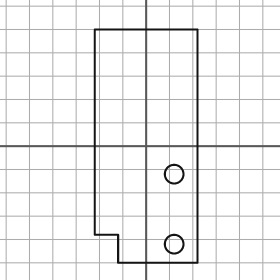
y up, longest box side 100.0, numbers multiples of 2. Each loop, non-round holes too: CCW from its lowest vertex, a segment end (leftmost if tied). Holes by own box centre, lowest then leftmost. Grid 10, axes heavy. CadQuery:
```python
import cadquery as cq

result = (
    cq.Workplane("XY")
    .moveTo(-12.0, -50.0)
    .lineTo(22.0, -50.0)
    .lineTo(22.0, 50.0)
    .lineTo(-22.0, 50.0)
    .lineTo(-22.0, -38.0)
    .lineTo(-12.0, -38.0)
    .close()
    .moveTo(12.0, -42.0)
    .circle(4.0)
    .moveTo(12.0, -12.0)
    .circle(4.0)
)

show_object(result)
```